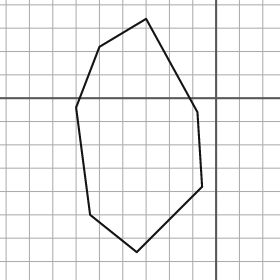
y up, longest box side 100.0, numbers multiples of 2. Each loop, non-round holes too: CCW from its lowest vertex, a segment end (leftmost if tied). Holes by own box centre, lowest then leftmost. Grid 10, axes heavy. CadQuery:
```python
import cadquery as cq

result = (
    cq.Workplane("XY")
    .moveTo(-34.0, -66.0)
    .lineTo(-6.0, -38.0)
    .lineTo(-8.0, -6.0)
    .lineTo(-30.0, 34.0)
    .lineTo(-50.0, 22.0)
    .lineTo(-60.0, -4.0)
    .lineTo(-54.0, -50.0)
    .close()
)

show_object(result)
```